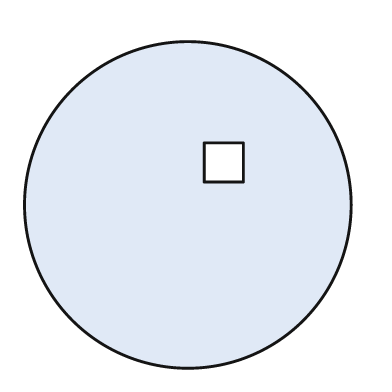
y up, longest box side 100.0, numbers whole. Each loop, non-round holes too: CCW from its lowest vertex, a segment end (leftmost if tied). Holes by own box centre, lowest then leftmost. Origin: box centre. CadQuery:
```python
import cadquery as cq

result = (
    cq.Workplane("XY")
    .moveTo(0.0, 0.0)
    .circle(50.0)
    .moveTo(5.0, 7.0)
    .lineTo(17.0, 7.0)
    .lineTo(17.0, 19.0)
    .lineTo(5.0, 19.0)
    .close()
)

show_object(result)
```